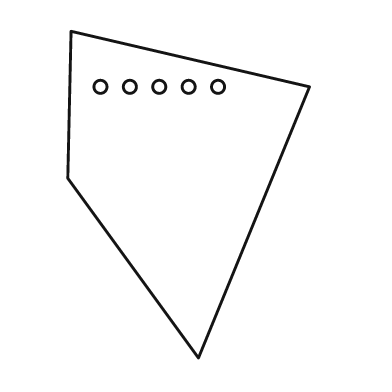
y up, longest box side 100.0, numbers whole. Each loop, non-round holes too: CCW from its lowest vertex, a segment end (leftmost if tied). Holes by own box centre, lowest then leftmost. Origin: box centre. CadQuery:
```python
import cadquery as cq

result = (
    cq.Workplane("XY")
    .moveTo(3.0, -50.0)
    .lineTo(37.0, 33.0)
    .lineTo(-36.0, 50.0)
    .lineTo(-37.0, 5.0)
    .close()
    .moveTo(-27.0, 33.0)
    .circle(2.0)
    .moveTo(-18.0, 33.0)
    .circle(2.0)
    .moveTo(-9.0, 33.0)
    .circle(2.0)
    .moveTo(0.0, 33.0)
    .circle(2.0)
    .moveTo(9.0, 33.0)
    .circle(2.0)
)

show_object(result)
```